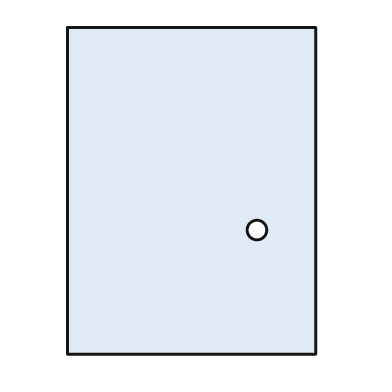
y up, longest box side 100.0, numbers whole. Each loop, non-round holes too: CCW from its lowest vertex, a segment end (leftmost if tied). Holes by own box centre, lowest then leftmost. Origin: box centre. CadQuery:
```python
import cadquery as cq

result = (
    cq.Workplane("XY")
    .moveTo(-38.0, -50.0)
    .lineTo(38.0, -50.0)
    .lineTo(38.0, 50.0)
    .lineTo(-38.0, 50.0)
    .close()
    .moveTo(20.0, -12.0)
    .circle(3.0)
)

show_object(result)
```